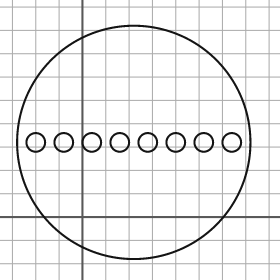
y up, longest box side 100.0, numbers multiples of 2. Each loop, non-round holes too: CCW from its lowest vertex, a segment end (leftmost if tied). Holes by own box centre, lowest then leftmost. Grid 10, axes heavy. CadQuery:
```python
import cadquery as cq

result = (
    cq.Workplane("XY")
    .moveTo(22.0, 32.0)
    .circle(50.0)
    .moveTo(-20.0, 32.0)
    .circle(4.0)
    .moveTo(-8.0, 32.0)
    .circle(4.0)
    .moveTo(4.0, 32.0)
    .circle(4.0)
    .moveTo(16.0, 32.0)
    .circle(4.0)
    .moveTo(28.0, 32.0)
    .circle(4.0)
    .moveTo(40.0, 32.0)
    .circle(4.0)
    .moveTo(52.0, 32.0)
    .circle(4.0)
    .moveTo(64.0, 32.0)
    .circle(4.0)
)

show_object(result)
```